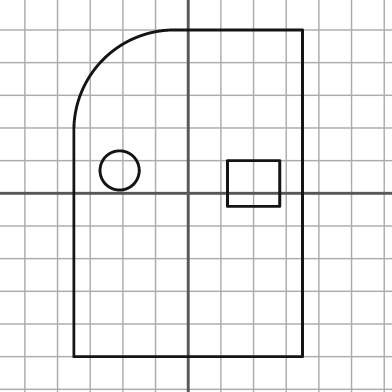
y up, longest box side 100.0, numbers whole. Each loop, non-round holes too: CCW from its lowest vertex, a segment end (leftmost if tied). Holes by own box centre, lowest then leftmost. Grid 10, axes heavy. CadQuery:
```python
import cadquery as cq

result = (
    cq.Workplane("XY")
    .moveTo(-35.0, -50.0)
    .lineTo(35.0, -50.0)
    .lineTo(35.0, 50.0)
    .lineTo(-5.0, 50.0)
    .threePointArc((-26.0, 41.0), (-35.0, 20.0))
    .close()
    .moveTo(12.0, -4.0)
    .lineTo(28.0, -4.0)
    .lineTo(28.0, 10.0)
    .lineTo(12.0, 10.0)
    .close()
    .moveTo(-21.0, 7.0)
    .circle(6.0)
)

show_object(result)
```